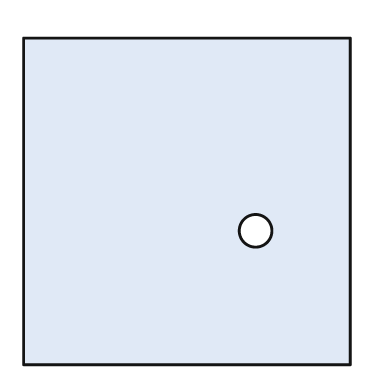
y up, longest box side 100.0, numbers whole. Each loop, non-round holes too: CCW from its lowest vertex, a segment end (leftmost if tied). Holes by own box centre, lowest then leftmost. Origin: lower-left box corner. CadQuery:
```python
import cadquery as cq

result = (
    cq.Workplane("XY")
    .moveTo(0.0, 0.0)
    .lineTo(100.0, 0.0)
    .lineTo(100.0, 100.0)
    .lineTo(0.0, 100.0)
    .close()
    .moveTo(71.0, 41.0)
    .circle(5.0)
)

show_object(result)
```